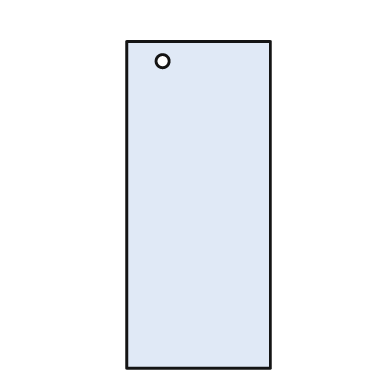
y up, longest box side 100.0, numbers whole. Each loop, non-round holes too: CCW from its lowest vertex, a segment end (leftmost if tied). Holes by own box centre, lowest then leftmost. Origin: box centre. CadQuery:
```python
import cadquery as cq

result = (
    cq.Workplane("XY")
    .moveTo(-22.0, -50.0)
    .lineTo(22.0, -50.0)
    .lineTo(22.0, 50.0)
    .lineTo(-22.0, 50.0)
    .close()
    .moveTo(-11.0, 44.0)
    .circle(2.0)
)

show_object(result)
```